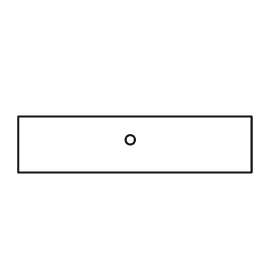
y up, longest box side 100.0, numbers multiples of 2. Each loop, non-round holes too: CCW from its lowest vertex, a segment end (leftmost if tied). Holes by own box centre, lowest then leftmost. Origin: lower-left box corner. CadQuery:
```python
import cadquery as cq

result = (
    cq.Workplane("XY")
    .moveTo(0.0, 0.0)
    .lineTo(100.0, 0.0)
    .lineTo(100.0, 24.0)
    .lineTo(0.0, 24.0)
    .close()
    .moveTo(48.0, 14.0)
    .circle(2.0)
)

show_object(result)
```